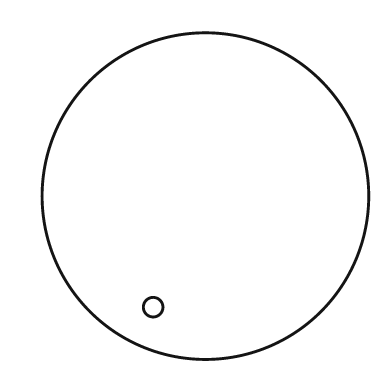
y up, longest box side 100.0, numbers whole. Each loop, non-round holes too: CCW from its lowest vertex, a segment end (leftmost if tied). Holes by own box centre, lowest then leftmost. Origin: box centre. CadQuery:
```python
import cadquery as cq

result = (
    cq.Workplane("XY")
    .moveTo(0.0, 0.0)
    .circle(50.0)
    .moveTo(-16.0, -34.0)
    .circle(3.0)
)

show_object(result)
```